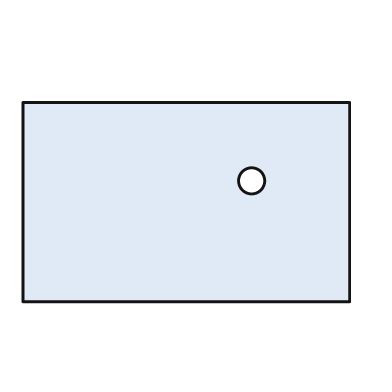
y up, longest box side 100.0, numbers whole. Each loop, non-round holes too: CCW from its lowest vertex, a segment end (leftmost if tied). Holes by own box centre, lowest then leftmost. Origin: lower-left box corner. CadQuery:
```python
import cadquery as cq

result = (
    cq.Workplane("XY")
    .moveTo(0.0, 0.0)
    .lineTo(100.0, 0.0)
    .lineTo(100.0, 61.0)
    .lineTo(0.0, 61.0)
    .close()
    .moveTo(70.0, 37.0)
    .circle(4.0)
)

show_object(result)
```